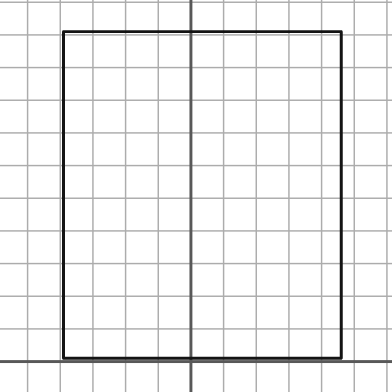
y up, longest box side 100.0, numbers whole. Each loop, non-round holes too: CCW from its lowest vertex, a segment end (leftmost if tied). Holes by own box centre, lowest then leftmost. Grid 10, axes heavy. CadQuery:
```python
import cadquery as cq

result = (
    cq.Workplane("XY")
    .moveTo(-39.0, 1.0)
    .lineTo(46.0, 1.0)
    .lineTo(46.0, 101.0)
    .lineTo(-39.0, 101.0)
    .close()
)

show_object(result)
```